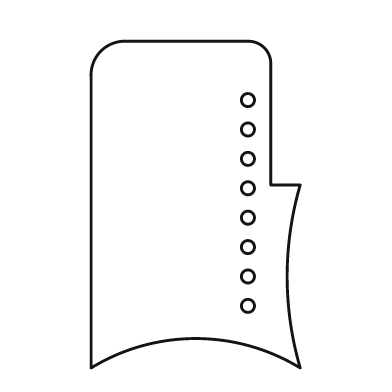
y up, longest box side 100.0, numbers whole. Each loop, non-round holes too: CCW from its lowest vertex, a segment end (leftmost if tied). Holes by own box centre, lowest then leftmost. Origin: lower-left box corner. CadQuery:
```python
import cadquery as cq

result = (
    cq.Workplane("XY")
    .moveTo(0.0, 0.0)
    .threePointArc((32.0, 9.0), (64.0, 0.0))
    .threePointArc((60.0, 28.0), (64.0, 56.0))
    .lineTo(55.0, 56.0)
    .lineTo(55.0, 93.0)
    .threePointArc((53.0, 98.0), (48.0, 100.0))
    .lineTo(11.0, 100.0)
    .threePointArc((3.0, 97.0), (0.0, 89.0))
    .close()
    .moveTo(48.0, 19.0)
    .circle(2.0)
    .moveTo(48.0, 28.0)
    .circle(2.0)
    .moveTo(48.0, 37.0)
    .circle(2.0)
    .moveTo(48.0, 46.0)
    .circle(2.0)
    .moveTo(48.0, 55.0)
    .circle(2.0)
    .moveTo(48.0, 64.0)
    .circle(2.0)
    .moveTo(48.0, 73.0)
    .circle(2.0)
    .moveTo(48.0, 82.0)
    .circle(2.0)
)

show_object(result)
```